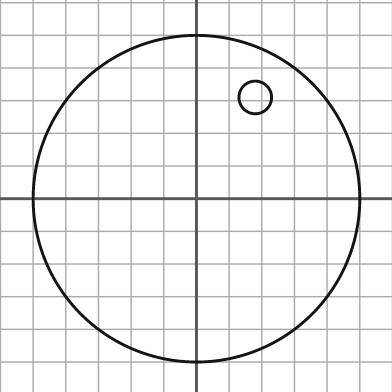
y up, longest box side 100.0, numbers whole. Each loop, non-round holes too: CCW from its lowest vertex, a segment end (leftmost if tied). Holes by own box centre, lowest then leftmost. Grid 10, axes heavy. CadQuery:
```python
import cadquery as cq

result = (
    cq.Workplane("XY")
    .moveTo(0.0, 0.0)
    .circle(50.0)
    .moveTo(18.0, 31.0)
    .circle(5.0)
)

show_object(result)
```